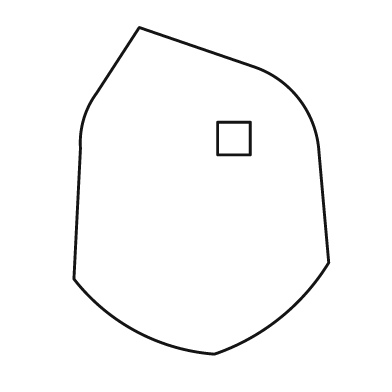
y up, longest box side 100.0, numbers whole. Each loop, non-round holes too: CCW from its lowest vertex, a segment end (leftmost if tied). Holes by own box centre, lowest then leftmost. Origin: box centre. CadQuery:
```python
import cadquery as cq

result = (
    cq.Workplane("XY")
    .moveTo(4.0, -50.0)
    .threePointArc((24.0, -39.0), (39.0, -22.0))
    .lineTo(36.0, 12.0)
    .threePointArc((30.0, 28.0), (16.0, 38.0))
    .lineTo(-19.0, 50.0)
    .lineTo(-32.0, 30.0)
    .threePointArc((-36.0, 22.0), (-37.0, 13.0))
    .lineTo(-39.0, -27.0)
    .threePointArc((-20.0, -43.0), (4.0, -50.0))
    .close()
    .moveTo(5.0, 11.0)
    .lineTo(15.0, 11.0)
    .lineTo(15.0, 21.0)
    .lineTo(5.0, 21.0)
    .close()
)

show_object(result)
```